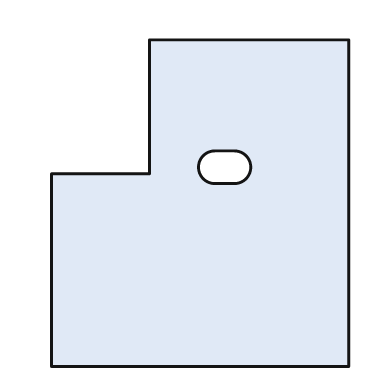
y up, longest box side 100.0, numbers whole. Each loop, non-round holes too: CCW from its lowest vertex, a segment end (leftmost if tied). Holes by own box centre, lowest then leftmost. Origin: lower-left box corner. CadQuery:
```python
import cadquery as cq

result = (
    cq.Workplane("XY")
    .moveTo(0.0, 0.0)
    .lineTo(91.0, 0.0)
    .lineTo(91.0, 100.0)
    .lineTo(30.0, 100.0)
    .lineTo(30.0, 59.0)
    .lineTo(0.0, 59.0)
    .close()
    .moveTo(50.0, 56.0)
    .lineTo(56.0, 56.0)
    .threePointArc((61.0, 61.0), (56.0, 66.0))
    .lineTo(50.0, 66.0)
    .threePointArc((45.0, 61.0), (50.0, 56.0))
    .close()
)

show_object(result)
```